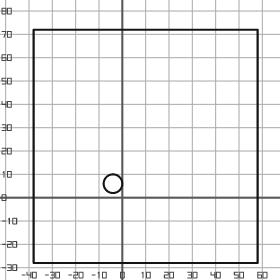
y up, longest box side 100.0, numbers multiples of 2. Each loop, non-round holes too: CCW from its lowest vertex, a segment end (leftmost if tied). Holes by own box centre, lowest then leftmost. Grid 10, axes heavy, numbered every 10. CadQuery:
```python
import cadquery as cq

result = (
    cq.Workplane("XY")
    .moveTo(-38.0, -28.0)
    .lineTo(58.0, -28.0)
    .lineTo(58.0, 72.0)
    .lineTo(-38.0, 72.0)
    .close()
    .moveTo(-4.0, 6.0)
    .circle(4.0)
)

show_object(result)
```